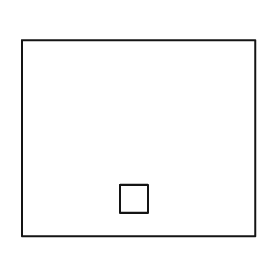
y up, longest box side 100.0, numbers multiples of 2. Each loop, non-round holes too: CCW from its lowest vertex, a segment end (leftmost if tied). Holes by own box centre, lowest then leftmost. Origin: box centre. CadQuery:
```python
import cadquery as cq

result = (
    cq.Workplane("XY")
    .moveTo(-50.0, -42.0)
    .lineTo(50.0, -42.0)
    .lineTo(50.0, 42.0)
    .lineTo(-50.0, 42.0)
    .close()
    .moveTo(-8.0, -32.0)
    .lineTo(4.0, -32.0)
    .lineTo(4.0, -20.0)
    .lineTo(-8.0, -20.0)
    .close()
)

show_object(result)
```